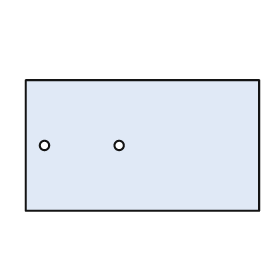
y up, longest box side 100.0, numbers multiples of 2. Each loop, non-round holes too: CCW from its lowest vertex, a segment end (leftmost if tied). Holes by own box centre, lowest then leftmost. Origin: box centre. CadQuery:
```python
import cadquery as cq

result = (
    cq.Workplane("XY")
    .moveTo(-50.0, -28.0)
    .lineTo(50.0, -28.0)
    .lineTo(50.0, 28.0)
    .lineTo(-50.0, 28.0)
    .close()
    .moveTo(-42.0, 0.0)
    .circle(2.0)
    .moveTo(-10.0, 0.0)
    .circle(2.0)
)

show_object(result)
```